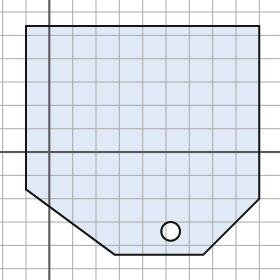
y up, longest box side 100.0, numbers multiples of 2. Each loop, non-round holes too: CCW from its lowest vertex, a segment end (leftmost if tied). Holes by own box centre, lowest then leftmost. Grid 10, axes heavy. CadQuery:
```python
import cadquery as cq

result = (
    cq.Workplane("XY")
    .moveTo(28.0, -44.0)
    .lineTo(66.0, -44.0)
    .lineTo(90.0, -20.0)
    .lineTo(90.0, 54.0)
    .lineTo(-10.0, 54.0)
    .lineTo(-10.0, -16.0)
    .close()
    .moveTo(52.0, -34.0)
    .circle(4.0)
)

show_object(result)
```